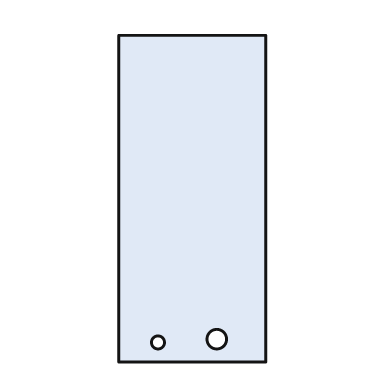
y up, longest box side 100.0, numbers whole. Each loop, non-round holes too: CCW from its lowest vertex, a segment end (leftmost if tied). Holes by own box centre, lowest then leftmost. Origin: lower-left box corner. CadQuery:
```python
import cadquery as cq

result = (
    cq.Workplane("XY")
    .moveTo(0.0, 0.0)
    .lineTo(45.0, 0.0)
    .lineTo(45.0, 100.0)
    .lineTo(0.0, 100.0)
    .close()
    .moveTo(12.0, 6.0)
    .circle(2.0)
    .moveTo(30.0, 7.0)
    .circle(3.0)
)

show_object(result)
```